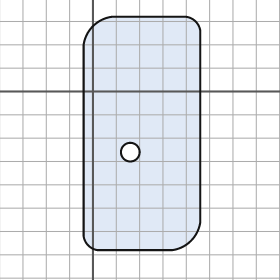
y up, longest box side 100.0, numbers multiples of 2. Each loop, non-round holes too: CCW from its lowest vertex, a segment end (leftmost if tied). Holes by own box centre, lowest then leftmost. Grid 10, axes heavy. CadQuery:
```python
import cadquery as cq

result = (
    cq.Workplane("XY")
    .moveTo(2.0, -68.0)
    .lineTo(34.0, -68.0)
    .threePointArc((42.0, -64.0), (46.0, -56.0))
    .lineTo(46.0, 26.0)
    .threePointArc((44.0, 30.0), (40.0, 32.0))
    .lineTo(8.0, 32.0)
    .threePointArc((0.0, 28.0), (-4.0, 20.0))
    .lineTo(-4.0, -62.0)
    .threePointArc((-2.0, -66.0), (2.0, -68.0))
    .close()
    .moveTo(16.0, -26.0)
    .circle(4.0)
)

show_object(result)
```